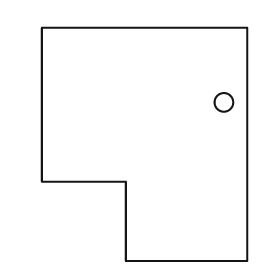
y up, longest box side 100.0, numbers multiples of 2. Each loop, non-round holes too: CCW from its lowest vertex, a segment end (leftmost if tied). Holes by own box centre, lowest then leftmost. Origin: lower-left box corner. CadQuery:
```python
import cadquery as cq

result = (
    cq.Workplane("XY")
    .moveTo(36.0, 0.0)
    .lineTo(88.0, 0.0)
    .lineTo(88.0, 100.0)
    .lineTo(0.0, 100.0)
    .lineTo(0.0, 34.0)
    .lineTo(36.0, 34.0)
    .close()
    .moveTo(78.0, 68.0)
    .circle(4.0)
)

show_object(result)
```